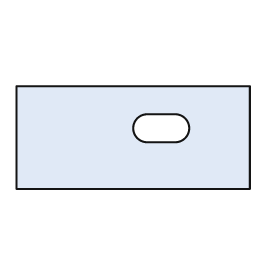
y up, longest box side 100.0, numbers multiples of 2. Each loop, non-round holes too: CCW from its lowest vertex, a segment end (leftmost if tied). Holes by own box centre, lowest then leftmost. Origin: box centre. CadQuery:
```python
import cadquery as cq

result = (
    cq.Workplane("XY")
    .moveTo(-50.0, -22.0)
    .lineTo(50.0, -22.0)
    .lineTo(50.0, 22.0)
    .lineTo(-50.0, 22.0)
    .close()
    .moveTo(6.0, -2.0)
    .lineTo(18.0, -2.0)
    .threePointArc((24.0, 4.0), (18.0, 10.0))
    .lineTo(6.0, 10.0)
    .threePointArc((0.0, 4.0), (6.0, -2.0))
    .close()
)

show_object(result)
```